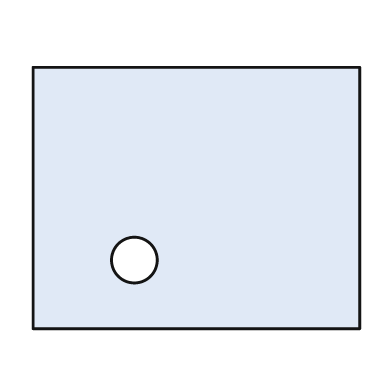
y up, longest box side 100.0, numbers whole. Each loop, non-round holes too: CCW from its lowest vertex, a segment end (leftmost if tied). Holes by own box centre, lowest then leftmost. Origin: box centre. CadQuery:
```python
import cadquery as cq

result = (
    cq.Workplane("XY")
    .moveTo(-50.0, -40.0)
    .lineTo(50.0, -40.0)
    .lineTo(50.0, 40.0)
    .lineTo(-50.0, 40.0)
    .close()
    .moveTo(-19.0, -19.0)
    .circle(7.0)
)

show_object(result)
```